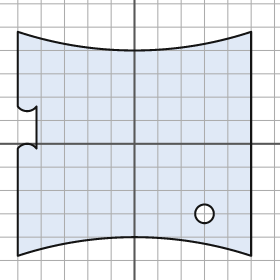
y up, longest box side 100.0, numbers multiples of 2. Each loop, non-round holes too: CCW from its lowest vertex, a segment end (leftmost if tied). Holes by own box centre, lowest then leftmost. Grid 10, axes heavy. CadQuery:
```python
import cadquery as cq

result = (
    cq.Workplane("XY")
    .moveTo(-50.0, -48.0)
    .threePointArc((0.0, -40.0), (50.0, -48.0))
    .lineTo(50.0, 48.0)
    .threePointArc((0.0, 40.0), (-50.0, 48.0))
    .lineTo(-50.0, 16.0)
    .threePointArc((-46.0, 14.0), (-42.0, 16.0))
    .lineTo(-42.0, -2.0)
    .threePointArc((-46.0, 0.0), (-50.0, -2.0))
    .close()
    .moveTo(30.0, -30.0)
    .circle(4.0)
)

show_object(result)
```